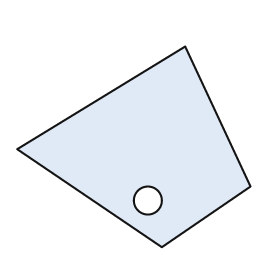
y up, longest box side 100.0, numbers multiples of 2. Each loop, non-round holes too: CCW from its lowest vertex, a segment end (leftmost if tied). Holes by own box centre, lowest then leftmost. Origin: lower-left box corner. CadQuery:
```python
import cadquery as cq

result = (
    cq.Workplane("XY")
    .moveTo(62.0, 0.0)
    .lineTo(100.0, 26.0)
    .lineTo(72.0, 86.0)
    .lineTo(0.0, 42.0)
    .close()
    .moveTo(56.0, 20.0)
    .circle(6.0)
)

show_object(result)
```